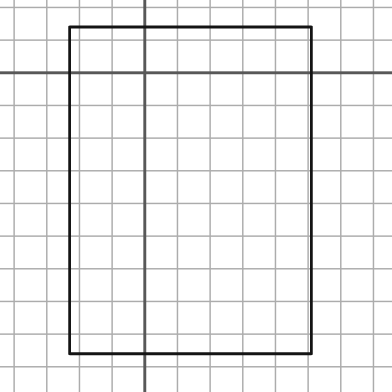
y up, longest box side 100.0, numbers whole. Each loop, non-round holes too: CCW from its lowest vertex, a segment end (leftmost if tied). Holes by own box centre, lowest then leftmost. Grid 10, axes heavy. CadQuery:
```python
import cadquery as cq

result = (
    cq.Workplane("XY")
    .moveTo(-23.0, -86.0)
    .lineTo(51.0, -86.0)
    .lineTo(51.0, 14.0)
    .lineTo(-23.0, 14.0)
    .close()
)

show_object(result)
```